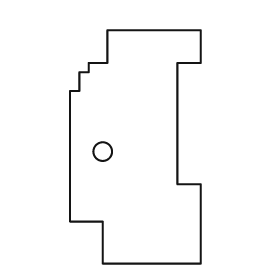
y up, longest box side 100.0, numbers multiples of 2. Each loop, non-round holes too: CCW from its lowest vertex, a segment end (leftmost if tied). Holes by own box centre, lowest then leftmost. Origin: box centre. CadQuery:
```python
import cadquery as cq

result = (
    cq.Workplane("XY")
    .moveTo(-14.0, -50.0)
    .lineTo(28.0, -50.0)
    .lineTo(28.0, -16.0)
    .lineTo(18.0, -16.0)
    .lineTo(18.0, 36.0)
    .lineTo(28.0, 36.0)
    .lineTo(28.0, 50.0)
    .lineTo(-12.0, 50.0)
    .lineTo(-12.0, 36.0)
    .lineTo(-20.0, 36.0)
    .lineTo(-20.0, 32.0)
    .lineTo(-24.0, 32.0)
    .lineTo(-24.0, 24.0)
    .lineTo(-28.0, 24.0)
    .lineTo(-28.0, -32.0)
    .lineTo(-14.0, -32.0)
    .close()
    .moveTo(-14.0, -2.0)
    .circle(4.0)
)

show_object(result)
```